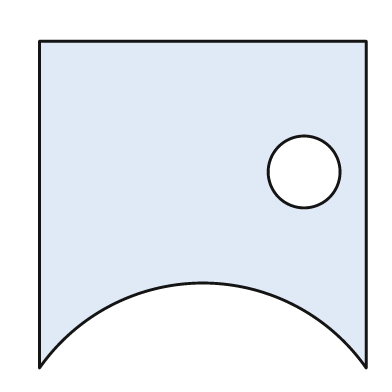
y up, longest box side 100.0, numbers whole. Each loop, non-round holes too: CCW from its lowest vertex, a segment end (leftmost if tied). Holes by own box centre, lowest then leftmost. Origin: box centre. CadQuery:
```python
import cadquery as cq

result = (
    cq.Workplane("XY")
    .moveTo(-50.0, -50.0)
    .threePointArc((0.0, -24.0), (50.0, -50.0))
    .lineTo(50.0, 50.0)
    .lineTo(-50.0, 50.0)
    .close()
    .moveTo(31.0, 10.0)
    .circle(11.0)
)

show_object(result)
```